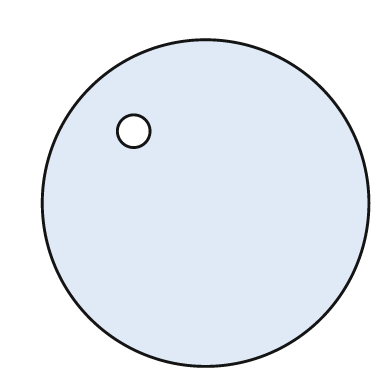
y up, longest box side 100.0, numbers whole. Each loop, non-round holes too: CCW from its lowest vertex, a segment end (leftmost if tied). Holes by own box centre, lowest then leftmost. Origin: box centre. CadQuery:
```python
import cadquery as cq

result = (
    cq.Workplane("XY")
    .moveTo(0.0, 0.0)
    .circle(50.0)
    .moveTo(-22.0, 22.0)
    .circle(5.0)
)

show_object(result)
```